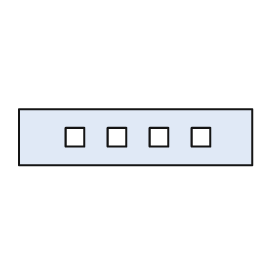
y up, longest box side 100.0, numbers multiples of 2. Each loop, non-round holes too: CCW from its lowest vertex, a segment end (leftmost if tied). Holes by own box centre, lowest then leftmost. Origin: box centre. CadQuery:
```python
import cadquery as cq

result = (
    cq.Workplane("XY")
    .moveTo(-50.0, -12.0)
    .lineTo(50.0, -12.0)
    .lineTo(50.0, 12.0)
    .lineTo(-50.0, 12.0)
    .close()
    .moveTo(-30.0, -4.0)
    .lineTo(-22.0, -4.0)
    .lineTo(-22.0, 4.0)
    .lineTo(-30.0, 4.0)
    .close()
    .moveTo(-12.0, -4.0)
    .lineTo(-4.0, -4.0)
    .lineTo(-4.0, 4.0)
    .lineTo(-12.0, 4.0)
    .close()
    .moveTo(6.0, -4.0)
    .lineTo(14.0, -4.0)
    .lineTo(14.0, 4.0)
    .lineTo(6.0, 4.0)
    .close()
    .moveTo(24.0, -4.0)
    .lineTo(32.0, -4.0)
    .lineTo(32.0, 4.0)
    .lineTo(24.0, 4.0)
    .close()
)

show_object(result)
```